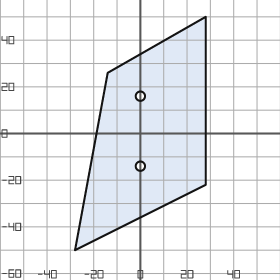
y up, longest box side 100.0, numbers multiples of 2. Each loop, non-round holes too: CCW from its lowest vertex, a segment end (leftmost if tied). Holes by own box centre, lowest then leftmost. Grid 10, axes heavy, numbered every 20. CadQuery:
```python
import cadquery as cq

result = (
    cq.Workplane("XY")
    .moveTo(-28.0, -50.0)
    .lineTo(28.0, -22.0)
    .lineTo(28.0, 50.0)
    .lineTo(-14.0, 26.0)
    .close()
    .moveTo(0.0, -14.0)
    .circle(2.0)
    .moveTo(0.0, 16.0)
    .circle(2.0)
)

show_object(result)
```